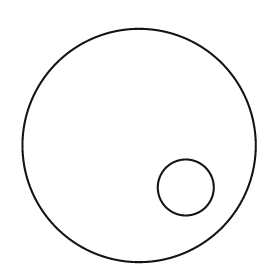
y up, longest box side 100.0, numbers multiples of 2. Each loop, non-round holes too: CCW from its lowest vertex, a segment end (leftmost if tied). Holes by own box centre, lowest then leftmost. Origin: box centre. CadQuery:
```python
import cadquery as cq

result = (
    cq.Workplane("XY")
    .moveTo(0.0, 0.0)
    .circle(50.0)
    .moveTo(20.0, -18.0)
    .circle(12.0)
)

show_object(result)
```